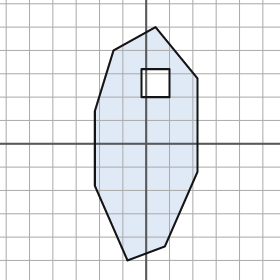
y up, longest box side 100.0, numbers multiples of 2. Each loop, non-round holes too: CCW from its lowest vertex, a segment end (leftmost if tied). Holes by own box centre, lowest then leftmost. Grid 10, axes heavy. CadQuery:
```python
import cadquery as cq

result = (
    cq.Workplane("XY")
    .moveTo(-8.0, -50.0)
    .lineTo(8.0, -44.0)
    .lineTo(22.0, -12.0)
    .lineTo(22.0, 28.0)
    .lineTo(4.0, 50.0)
    .lineTo(-14.0, 40.0)
    .lineTo(-22.0, 14.0)
    .lineTo(-22.0, -18.0)
    .close()
    .moveTo(-2.0, 20.0)
    .lineTo(10.0, 20.0)
    .lineTo(10.0, 32.0)
    .lineTo(-2.0, 32.0)
    .close()
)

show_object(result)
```